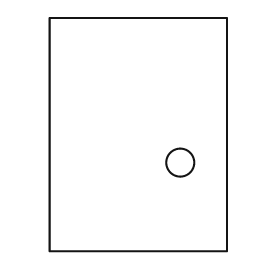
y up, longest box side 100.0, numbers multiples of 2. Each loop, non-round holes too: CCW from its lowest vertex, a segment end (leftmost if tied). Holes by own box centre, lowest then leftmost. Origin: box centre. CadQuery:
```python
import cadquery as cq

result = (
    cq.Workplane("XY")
    .moveTo(-38.0, -50.0)
    .lineTo(38.0, -50.0)
    .lineTo(38.0, 50.0)
    .lineTo(-38.0, 50.0)
    .close()
    .moveTo(18.0, -12.0)
    .circle(6.0)
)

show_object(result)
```